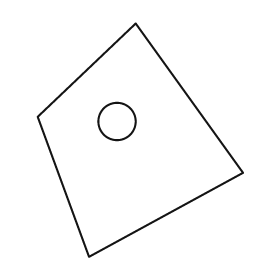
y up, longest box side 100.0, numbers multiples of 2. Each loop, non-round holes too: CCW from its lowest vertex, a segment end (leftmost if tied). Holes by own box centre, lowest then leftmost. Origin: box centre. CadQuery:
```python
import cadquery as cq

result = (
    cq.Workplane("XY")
    .moveTo(-22.0, -50.0)
    .lineTo(44.0, -14.0)
    .lineTo(-2.0, 50.0)
    .lineTo(-44.0, 10.0)
    .close()
    .moveTo(-10.0, 8.0)
    .circle(8.0)
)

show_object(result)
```